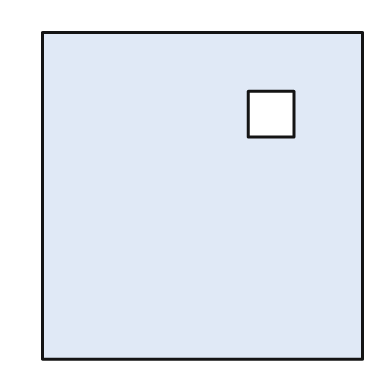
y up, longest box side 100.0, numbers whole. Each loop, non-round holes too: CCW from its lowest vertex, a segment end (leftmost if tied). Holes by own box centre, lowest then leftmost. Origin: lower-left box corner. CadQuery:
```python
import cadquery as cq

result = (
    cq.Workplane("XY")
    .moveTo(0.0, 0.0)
    .lineTo(98.0, 0.0)
    .lineTo(98.0, 100.0)
    .lineTo(0.0, 100.0)
    .close()
    .moveTo(63.0, 68.0)
    .lineTo(77.0, 68.0)
    .lineTo(77.0, 82.0)
    .lineTo(63.0, 82.0)
    .close()
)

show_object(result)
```